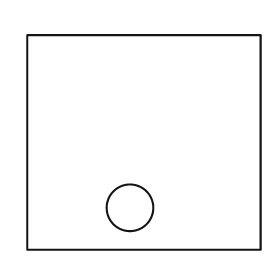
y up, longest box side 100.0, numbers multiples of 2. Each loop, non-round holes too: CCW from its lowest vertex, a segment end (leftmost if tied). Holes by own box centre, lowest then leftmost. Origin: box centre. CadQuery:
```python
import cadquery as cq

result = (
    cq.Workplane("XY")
    .moveTo(-50.0, -46.0)
    .lineTo(50.0, -46.0)
    .lineTo(50.0, 46.0)
    .lineTo(-50.0, 46.0)
    .close()
    .moveTo(-6.0, -28.0)
    .circle(10.0)
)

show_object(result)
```